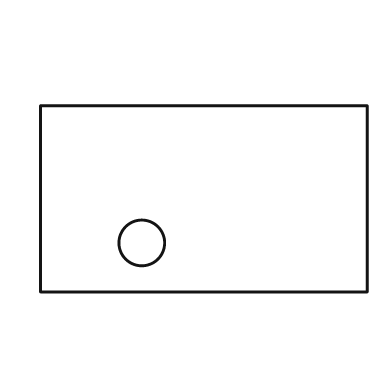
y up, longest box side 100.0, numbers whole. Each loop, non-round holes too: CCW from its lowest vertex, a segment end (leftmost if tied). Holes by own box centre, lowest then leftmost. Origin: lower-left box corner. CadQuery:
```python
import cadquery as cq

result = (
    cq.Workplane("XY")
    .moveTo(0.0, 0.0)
    .lineTo(100.0, 0.0)
    .lineTo(100.0, 57.0)
    .lineTo(0.0, 57.0)
    .close()
    .moveTo(31.0, 15.0)
    .circle(7.0)
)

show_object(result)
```